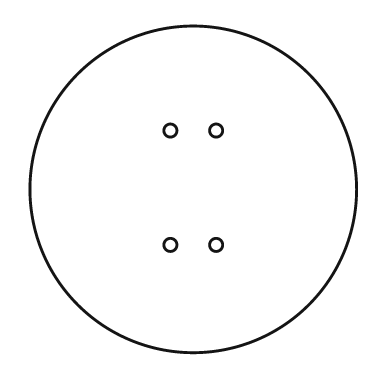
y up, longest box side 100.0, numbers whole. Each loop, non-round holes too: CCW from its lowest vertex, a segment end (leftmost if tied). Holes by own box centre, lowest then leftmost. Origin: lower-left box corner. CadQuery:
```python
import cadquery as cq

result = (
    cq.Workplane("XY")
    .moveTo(50.0, 50.0)
    .circle(50.0)
    .moveTo(43.0, 33.0)
    .circle(2.0)
    .moveTo(57.0, 33.0)
    .circle(2.0)
    .moveTo(43.0, 68.0)
    .circle(2.0)
    .moveTo(57.0, 68.0)
    .circle(2.0)
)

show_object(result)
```